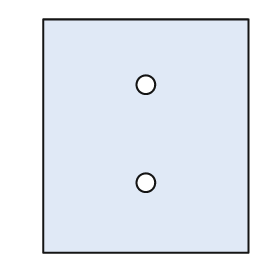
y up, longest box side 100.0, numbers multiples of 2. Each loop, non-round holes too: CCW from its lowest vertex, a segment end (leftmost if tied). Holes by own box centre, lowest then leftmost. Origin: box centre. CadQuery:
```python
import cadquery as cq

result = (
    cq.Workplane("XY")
    .moveTo(-44.0, -50.0)
    .lineTo(44.0, -50.0)
    .lineTo(44.0, 50.0)
    .lineTo(-44.0, 50.0)
    .close()
    .moveTo(0.0, -20.0)
    .circle(4.0)
    .moveTo(0.0, 22.0)
    .circle(4.0)
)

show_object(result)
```